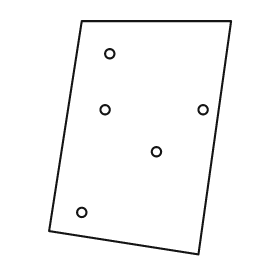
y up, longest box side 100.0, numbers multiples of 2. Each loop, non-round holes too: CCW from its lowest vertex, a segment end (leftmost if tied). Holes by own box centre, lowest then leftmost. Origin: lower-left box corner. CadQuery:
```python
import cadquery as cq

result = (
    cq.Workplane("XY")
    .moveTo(64.0, 0.0)
    .lineTo(78.0, 100.0)
    .lineTo(14.0, 100.0)
    .lineTo(0.0, 10.0)
    .close()
    .moveTo(14.0, 18.0)
    .circle(2.0)
    .moveTo(46.0, 44.0)
    .circle(2.0)
    .moveTo(24.0, 62.0)
    .circle(2.0)
    .moveTo(66.0, 62.0)
    .circle(2.0)
    .moveTo(26.0, 86.0)
    .circle(2.0)
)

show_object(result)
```